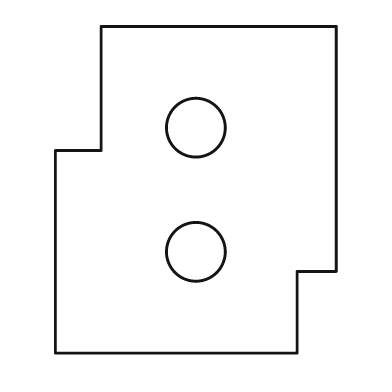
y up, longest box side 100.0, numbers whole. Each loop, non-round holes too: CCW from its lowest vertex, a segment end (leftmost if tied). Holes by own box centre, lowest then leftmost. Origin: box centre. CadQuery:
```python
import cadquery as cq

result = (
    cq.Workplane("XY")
    .moveTo(-43.0, -50.0)
    .lineTo(31.0, -50.0)
    .lineTo(31.0, -25.0)
    .lineTo(43.0, -25.0)
    .lineTo(43.0, 50.0)
    .lineTo(-29.0, 50.0)
    .lineTo(-29.0, 12.0)
    .lineTo(-43.0, 12.0)
    .close()
    .moveTo(0.0, -19.0)
    .circle(9.0)
    .moveTo(0.0, 19.0)
    .circle(9.0)
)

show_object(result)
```